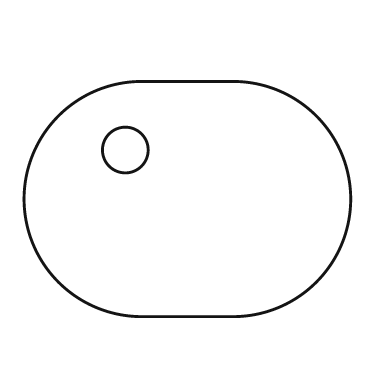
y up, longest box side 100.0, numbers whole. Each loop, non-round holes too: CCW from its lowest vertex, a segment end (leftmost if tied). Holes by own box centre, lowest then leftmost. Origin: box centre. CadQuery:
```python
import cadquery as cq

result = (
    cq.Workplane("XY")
    .moveTo(-14.0, -36.0)
    .lineTo(14.0, -36.0)
    .threePointArc((50.0, 0.0), (14.0, 36.0))
    .lineTo(-14.0, 36.0)
    .threePointArc((-50.0, 0.0), (-14.0, -36.0))
    .close()
    .moveTo(-19.0, 15.0)
    .circle(7.0)
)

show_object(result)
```